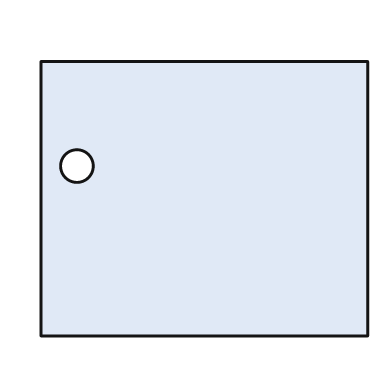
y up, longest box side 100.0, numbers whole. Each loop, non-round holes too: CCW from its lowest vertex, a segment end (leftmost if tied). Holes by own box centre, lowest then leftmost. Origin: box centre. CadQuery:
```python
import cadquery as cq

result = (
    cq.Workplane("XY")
    .moveTo(-50.0, -42.0)
    .lineTo(50.0, -42.0)
    .lineTo(50.0, 42.0)
    .lineTo(-50.0, 42.0)
    .close()
    .moveTo(-39.0, 10.0)
    .circle(5.0)
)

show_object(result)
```